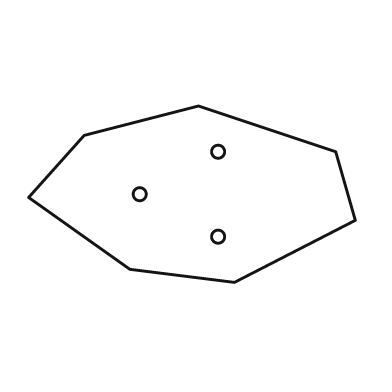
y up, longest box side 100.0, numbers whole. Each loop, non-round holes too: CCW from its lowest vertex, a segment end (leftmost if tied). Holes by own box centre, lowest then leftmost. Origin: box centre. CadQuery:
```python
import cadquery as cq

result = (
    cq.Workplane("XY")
    .moveTo(13.0, -27.0)
    .lineTo(50.0, -8.0)
    .lineTo(44.0, 13.0)
    .lineTo(2.0, 27.0)
    .lineTo(-33.0, 18.0)
    .lineTo(-50.0, -1.0)
    .lineTo(-19.0, -23.0)
    .close()
    .moveTo(8.0, -13.0)
    .circle(2.0)
    .moveTo(-16.0, 0.0)
    .circle(2.0)
    .moveTo(8.0, 13.0)
    .circle(2.0)
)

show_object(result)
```